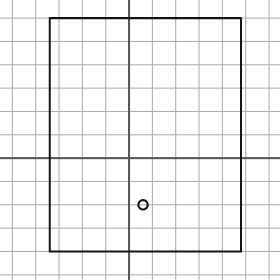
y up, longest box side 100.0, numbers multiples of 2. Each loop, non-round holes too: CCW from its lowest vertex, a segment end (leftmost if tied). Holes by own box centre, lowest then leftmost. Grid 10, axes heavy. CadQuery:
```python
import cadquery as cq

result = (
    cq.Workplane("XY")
    .moveTo(-34.0, -40.0)
    .lineTo(48.0, -40.0)
    .lineTo(48.0, 60.0)
    .lineTo(-34.0, 60.0)
    .close()
    .moveTo(6.0, -20.0)
    .circle(2.0)
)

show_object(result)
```